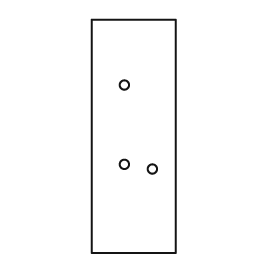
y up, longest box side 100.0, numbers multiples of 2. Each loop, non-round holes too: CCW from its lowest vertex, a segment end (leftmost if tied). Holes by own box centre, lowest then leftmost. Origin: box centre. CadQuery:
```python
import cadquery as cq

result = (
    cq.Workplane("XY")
    .moveTo(-18.0, -50.0)
    .lineTo(18.0, -50.0)
    .lineTo(18.0, 50.0)
    .lineTo(-18.0, 50.0)
    .close()
    .moveTo(8.0, -14.0)
    .circle(2.0)
    .moveTo(-4.0, -12.0)
    .circle(2.0)
    .moveTo(-4.0, 22.0)
    .circle(2.0)
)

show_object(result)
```